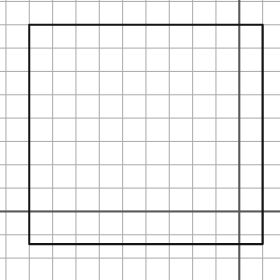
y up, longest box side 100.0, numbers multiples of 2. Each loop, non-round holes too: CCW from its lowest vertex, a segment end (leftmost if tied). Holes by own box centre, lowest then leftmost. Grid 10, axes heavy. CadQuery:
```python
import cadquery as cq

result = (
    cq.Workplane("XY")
    .moveTo(-90.0, -14.0)
    .lineTo(10.0, -14.0)
    .lineTo(10.0, 80.0)
    .lineTo(-90.0, 80.0)
    .close()
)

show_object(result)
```